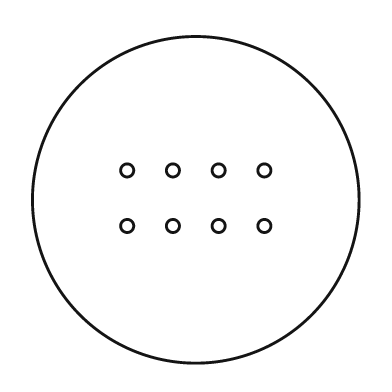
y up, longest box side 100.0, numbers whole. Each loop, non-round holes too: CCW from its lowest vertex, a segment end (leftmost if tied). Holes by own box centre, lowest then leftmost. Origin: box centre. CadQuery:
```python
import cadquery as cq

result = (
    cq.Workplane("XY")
    .moveTo(0.0, 0.0)
    .circle(50.0)
    .moveTo(-21.0, -8.0)
    .circle(2.0)
    .moveTo(-7.0, -8.0)
    .circle(2.0)
    .moveTo(7.0, -8.0)
    .circle(2.0)
    .moveTo(21.0, -8.0)
    .circle(2.0)
    .moveTo(-21.0, 9.0)
    .circle(2.0)
    .moveTo(-7.0, 9.0)
    .circle(2.0)
    .moveTo(7.0, 9.0)
    .circle(2.0)
    .moveTo(21.0, 9.0)
    .circle(2.0)
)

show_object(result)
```